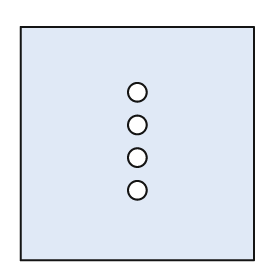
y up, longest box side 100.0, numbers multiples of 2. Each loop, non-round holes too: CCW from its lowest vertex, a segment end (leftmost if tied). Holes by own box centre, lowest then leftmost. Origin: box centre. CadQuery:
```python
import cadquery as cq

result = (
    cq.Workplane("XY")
    .moveTo(-50.0, -50.0)
    .lineTo(50.0, -50.0)
    .lineTo(50.0, 50.0)
    .lineTo(-50.0, 50.0)
    .close()
    .moveTo(0.0, -20.0)
    .circle(4.0)
    .moveTo(0.0, -6.0)
    .circle(4.0)
    .moveTo(0.0, 8.0)
    .circle(4.0)
    .moveTo(0.0, 22.0)
    .circle(4.0)
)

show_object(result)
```